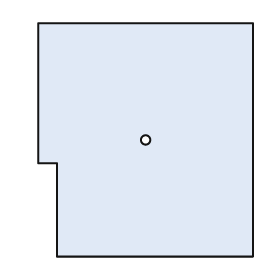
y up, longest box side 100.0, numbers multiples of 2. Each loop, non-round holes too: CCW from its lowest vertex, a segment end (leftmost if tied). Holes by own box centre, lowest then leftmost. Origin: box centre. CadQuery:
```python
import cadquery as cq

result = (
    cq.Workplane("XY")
    .moveTo(-38.0, -50.0)
    .lineTo(46.0, -50.0)
    .lineTo(46.0, 50.0)
    .lineTo(-46.0, 50.0)
    .lineTo(-46.0, -10.0)
    .lineTo(-38.0, -10.0)
    .close()
    .moveTo(0.0, 0.0)
    .circle(2.0)
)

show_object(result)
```